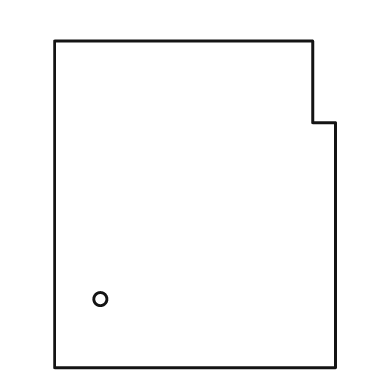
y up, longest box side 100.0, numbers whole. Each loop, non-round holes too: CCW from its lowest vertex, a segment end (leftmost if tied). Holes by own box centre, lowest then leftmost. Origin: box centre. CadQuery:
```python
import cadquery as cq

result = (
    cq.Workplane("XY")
    .moveTo(-43.0, -50.0)
    .lineTo(43.0, -50.0)
    .lineTo(43.0, 25.0)
    .lineTo(36.0, 25.0)
    .lineTo(36.0, 50.0)
    .lineTo(-43.0, 50.0)
    .close()
    .moveTo(-29.0, -29.0)
    .circle(2.0)
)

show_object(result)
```